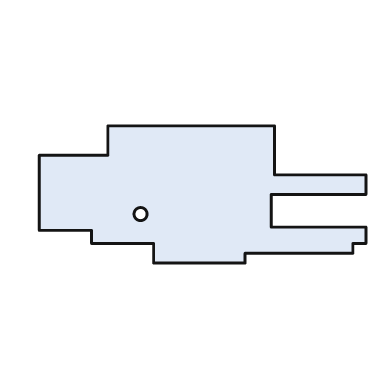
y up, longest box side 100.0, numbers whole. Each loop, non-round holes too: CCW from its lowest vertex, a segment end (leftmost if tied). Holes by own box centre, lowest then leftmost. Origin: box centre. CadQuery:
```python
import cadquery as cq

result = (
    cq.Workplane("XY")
    .moveTo(-15.0, -21.0)
    .lineTo(13.0, -21.0)
    .lineTo(13.0, -18.0)
    .lineTo(46.0, -18.0)
    .lineTo(46.0, -15.0)
    .lineTo(50.0, -15.0)
    .lineTo(50.0, -10.0)
    .lineTo(21.0, -10.0)
    .lineTo(21.0, 0.0)
    .lineTo(50.0, 0.0)
    .lineTo(50.0, 6.0)
    .lineTo(22.0, 6.0)
    .lineTo(22.0, 21.0)
    .lineTo(-29.0, 21.0)
    .lineTo(-29.0, 12.0)
    .lineTo(-50.0, 12.0)
    .lineTo(-50.0, -11.0)
    .lineTo(-34.0, -11.0)
    .lineTo(-34.0, -15.0)
    .lineTo(-15.0, -15.0)
    .close()
    .moveTo(-19.0, -6.0)
    .circle(2.0)
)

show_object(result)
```